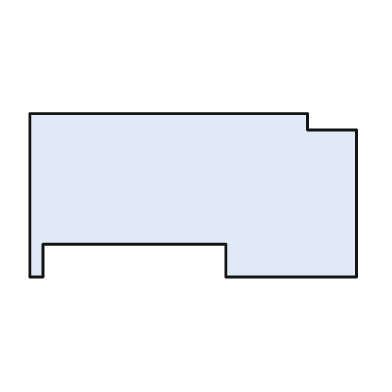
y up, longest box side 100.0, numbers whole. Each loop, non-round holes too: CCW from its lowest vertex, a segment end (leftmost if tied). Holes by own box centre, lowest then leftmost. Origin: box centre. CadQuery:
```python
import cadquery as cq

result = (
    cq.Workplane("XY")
    .moveTo(-50.0, -25.0)
    .lineTo(-46.0, -25.0)
    .lineTo(-46.0, -15.0)
    .lineTo(10.0, -15.0)
    .lineTo(10.0, -25.0)
    .lineTo(50.0, -25.0)
    .lineTo(50.0, 20.0)
    .lineTo(35.0, 20.0)
    .lineTo(35.0, 25.0)
    .lineTo(-50.0, 25.0)
    .close()
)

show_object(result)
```